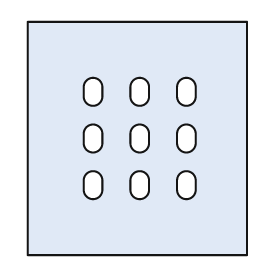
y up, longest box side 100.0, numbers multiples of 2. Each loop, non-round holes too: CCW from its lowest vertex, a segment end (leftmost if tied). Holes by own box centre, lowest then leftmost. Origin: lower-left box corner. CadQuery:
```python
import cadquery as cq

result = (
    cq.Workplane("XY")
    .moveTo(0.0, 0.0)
    .lineTo(94.0, 0.0)
    .lineTo(94.0, 100.0)
    .lineTo(0.0, 100.0)
    .close()
    .moveTo(24.0, 28.0)
    .threePointArc((28.0, 24.0), (32.0, 28.0))
    .lineTo(32.0, 32.0)
    .threePointArc((28.0, 36.0), (24.0, 32.0))
    .close()
    .moveTo(44.0, 28.0)
    .threePointArc((48.0, 24.0), (52.0, 28.0))
    .lineTo(52.0, 32.0)
    .threePointArc((48.0, 36.0), (44.0, 32.0))
    .close()
    .moveTo(64.0, 28.0)
    .threePointArc((68.0, 24.0), (72.0, 28.0))
    .lineTo(72.0, 32.0)
    .threePointArc((68.0, 36.0), (64.0, 32.0))
    .close()
    .moveTo(24.0, 48.0)
    .threePointArc((28.0, 44.0), (32.0, 48.0))
    .lineTo(32.0, 52.0)
    .threePointArc((28.0, 56.0), (24.0, 52.0))
    .close()
    .moveTo(44.0, 48.0)
    .threePointArc((48.0, 44.0), (52.0, 48.0))
    .lineTo(52.0, 52.0)
    .threePointArc((48.0, 56.0), (44.0, 52.0))
    .close()
    .moveTo(64.0, 48.0)
    .threePointArc((68.0, 44.0), (72.0, 48.0))
    .lineTo(72.0, 52.0)
    .threePointArc((68.0, 56.0), (64.0, 52.0))
    .close()
    .moveTo(24.0, 68.0)
    .threePointArc((28.0, 64.0), (32.0, 68.0))
    .lineTo(32.0, 72.0)
    .threePointArc((28.0, 76.0), (24.0, 72.0))
    .close()
    .moveTo(44.0, 68.0)
    .threePointArc((48.0, 64.0), (52.0, 68.0))
    .lineTo(52.0, 72.0)
    .threePointArc((48.0, 76.0), (44.0, 72.0))
    .close()
    .moveTo(64.0, 68.0)
    .threePointArc((68.0, 64.0), (72.0, 68.0))
    .lineTo(72.0, 72.0)
    .threePointArc((68.0, 76.0), (64.0, 72.0))
    .close()
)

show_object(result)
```